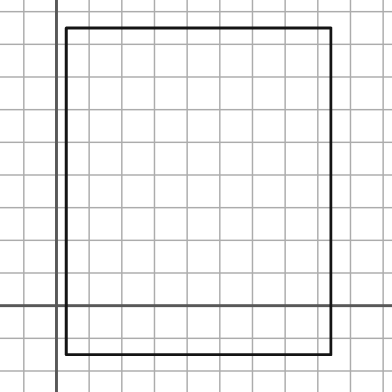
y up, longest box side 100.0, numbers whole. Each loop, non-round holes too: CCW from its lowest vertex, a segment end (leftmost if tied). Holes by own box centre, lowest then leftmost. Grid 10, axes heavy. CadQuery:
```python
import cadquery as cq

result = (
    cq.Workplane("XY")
    .moveTo(3.0, -15.0)
    .lineTo(84.0, -15.0)
    .lineTo(84.0, 85.0)
    .lineTo(3.0, 85.0)
    .close()
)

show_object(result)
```